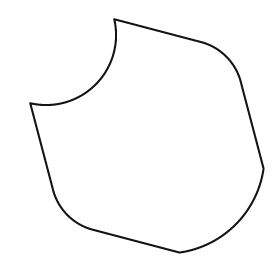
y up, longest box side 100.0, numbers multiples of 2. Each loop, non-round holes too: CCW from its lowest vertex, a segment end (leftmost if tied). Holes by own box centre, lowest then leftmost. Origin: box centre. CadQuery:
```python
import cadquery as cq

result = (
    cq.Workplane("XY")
    .moveTo(14.0, -50.0)
    .threePointArc((38.0, -38.0), (50.0, -14.0))
    .lineTo(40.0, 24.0)
    .threePointArc((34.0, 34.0), (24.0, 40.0))
    .lineTo(-14.0, 50.0)
    .threePointArc((-22.0, 22.0), (-50.0, 14.0))
    .lineTo(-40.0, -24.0)
    .threePointArc((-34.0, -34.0), (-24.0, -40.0))
    .close()
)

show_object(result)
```